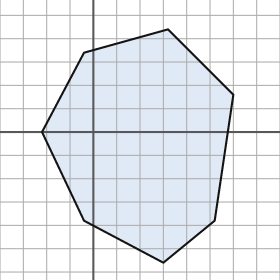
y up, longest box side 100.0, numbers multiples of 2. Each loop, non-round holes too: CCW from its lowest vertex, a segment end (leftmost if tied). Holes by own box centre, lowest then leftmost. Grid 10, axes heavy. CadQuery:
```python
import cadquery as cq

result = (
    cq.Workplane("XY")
    .moveTo(30.0, -56.0)
    .lineTo(52.0, -38.0)
    .lineTo(60.0, 16.0)
    .lineTo(32.0, 44.0)
    .lineTo(-4.0, 34.0)
    .lineTo(-22.0, 0.0)
    .lineTo(-4.0, -38.0)
    .close()
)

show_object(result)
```